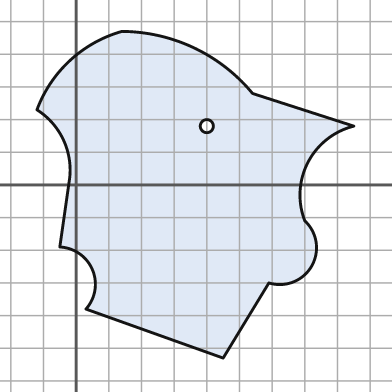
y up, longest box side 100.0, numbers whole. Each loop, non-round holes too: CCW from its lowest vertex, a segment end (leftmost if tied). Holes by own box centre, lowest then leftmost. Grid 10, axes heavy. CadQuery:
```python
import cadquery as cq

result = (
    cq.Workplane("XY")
    .moveTo(45.0, -53.0)
    .lineTo(59.0, -30.0)
    .threePointArc((72.0, -25.0), (70.0, -11.0))
    .threePointArc((71.0, 7.0), (85.0, 18.0))
    .lineTo(54.0, 28.0)
    .threePointArc((36.0, 42.0), (14.0, 47.0))
    .threePointArc((-2.0, 38.0), (-12.0, 23.0))
    .threePointArc((-4.0, 14.0), (-2.0, 2.0))
    .lineTo(-5.0, -19.0)
    .threePointArc((5.0, -26.0), (3.0, -38.0))
    .close()
    .moveTo(40.0, 18.0)
    .circle(2.0)
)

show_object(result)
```